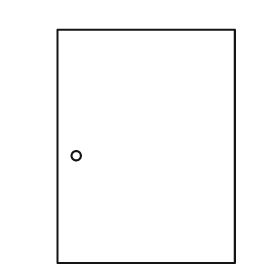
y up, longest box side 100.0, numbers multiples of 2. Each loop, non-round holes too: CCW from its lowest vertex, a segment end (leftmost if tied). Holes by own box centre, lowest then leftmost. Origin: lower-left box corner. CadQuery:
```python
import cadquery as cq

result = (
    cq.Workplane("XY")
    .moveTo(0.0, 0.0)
    .lineTo(76.0, 0.0)
    .lineTo(76.0, 100.0)
    .lineTo(0.0, 100.0)
    .close()
    .moveTo(8.0, 46.0)
    .circle(2.0)
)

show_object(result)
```